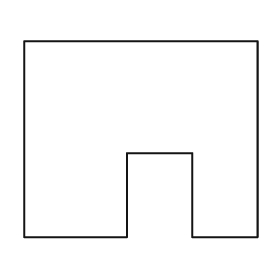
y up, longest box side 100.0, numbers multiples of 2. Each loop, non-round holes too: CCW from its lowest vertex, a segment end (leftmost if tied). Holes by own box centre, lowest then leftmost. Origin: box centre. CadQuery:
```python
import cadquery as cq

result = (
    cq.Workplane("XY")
    .moveTo(-50.0, -42.0)
    .lineTo(-6.0, -42.0)
    .lineTo(-6.0, -6.0)
    .lineTo(22.0, -6.0)
    .lineTo(22.0, -42.0)
    .lineTo(50.0, -42.0)
    .lineTo(50.0, 42.0)
    .lineTo(-50.0, 42.0)
    .close()
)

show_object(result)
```